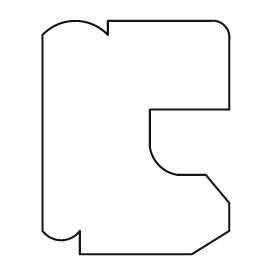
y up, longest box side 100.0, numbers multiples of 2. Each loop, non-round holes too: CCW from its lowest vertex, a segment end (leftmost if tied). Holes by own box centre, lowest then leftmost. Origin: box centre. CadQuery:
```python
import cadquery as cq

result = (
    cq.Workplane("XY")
    .moveTo(-24.0, -50.0)
    .lineTo(24.0, -50.0)
    .lineTo(40.0, -40.0)
    .lineTo(40.0, -28.0)
    .lineTo(30.0, -16.0)
    .lineTo(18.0, -16.0)
    .threePointArc((10.0, -12.0), (6.0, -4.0))
    .lineTo(6.0, 12.0)
    .lineTo(40.0, 12.0)
    .lineTo(40.0, 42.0)
    .threePointArc((38.0, 48.0), (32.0, 50.0))
    .lineTo(-12.0, 50.0)
    .lineTo(-12.0, 44.0)
    .threePointArc((-26.0, 50.0), (-40.0, 44.0))
    .lineTo(-40.0, -40.0)
    .threePointArc((-32.0, -44.0), (-24.0, -40.0))
    .close()
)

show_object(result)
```